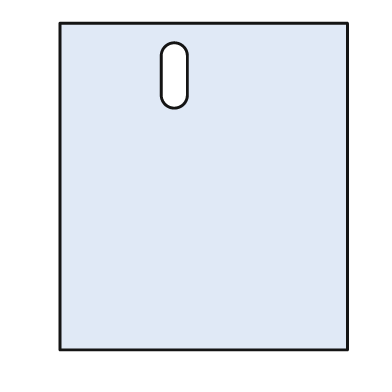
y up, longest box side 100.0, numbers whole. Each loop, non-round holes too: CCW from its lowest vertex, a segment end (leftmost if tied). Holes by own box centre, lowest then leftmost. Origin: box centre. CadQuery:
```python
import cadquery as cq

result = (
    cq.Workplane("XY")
    .moveTo(-44.0, -50.0)
    .lineTo(44.0, -50.0)
    .lineTo(44.0, 50.0)
    .lineTo(-44.0, 50.0)
    .close()
    .moveTo(-13.0, 28.0)
    .threePointArc((-9.0, 24.0), (-5.0, 28.0))
    .lineTo(-5.0, 40.0)
    .threePointArc((-9.0, 44.0), (-13.0, 40.0))
    .close()
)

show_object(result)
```